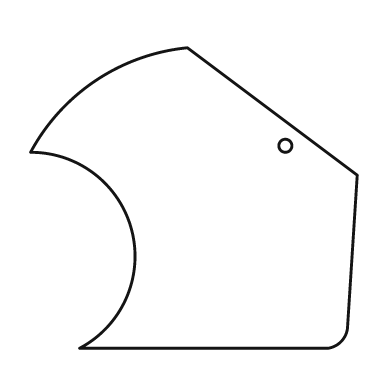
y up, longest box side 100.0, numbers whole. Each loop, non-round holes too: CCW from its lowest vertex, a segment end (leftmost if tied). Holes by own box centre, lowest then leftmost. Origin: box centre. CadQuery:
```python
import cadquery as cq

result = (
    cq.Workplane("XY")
    .moveTo(-35.0, -46.0)
    .lineTo(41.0, -46.0)
    .threePointArc((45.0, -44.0), (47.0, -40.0))
    .lineTo(50.0, 7.0)
    .lineTo(-2.0, 46.0)
    .threePointArc((-30.0, 36.0), (-50.0, 14.0))
    .threePointArc((-19.0, -10.0), (-35.0, -46.0))
    .close()
    .moveTo(28.0, 16.0)
    .circle(2.0)
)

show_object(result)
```